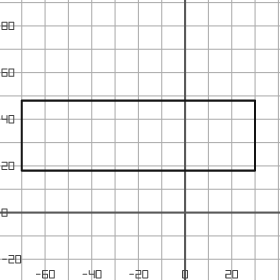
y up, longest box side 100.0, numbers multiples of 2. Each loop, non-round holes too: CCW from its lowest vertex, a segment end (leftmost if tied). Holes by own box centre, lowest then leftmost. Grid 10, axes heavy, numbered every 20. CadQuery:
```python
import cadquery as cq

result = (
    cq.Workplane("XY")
    .moveTo(-70.0, 18.0)
    .lineTo(30.0, 18.0)
    .lineTo(30.0, 48.0)
    .lineTo(-70.0, 48.0)
    .close()
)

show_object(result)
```